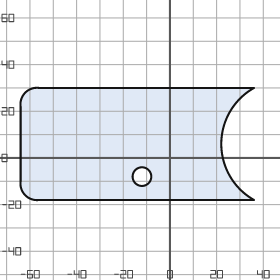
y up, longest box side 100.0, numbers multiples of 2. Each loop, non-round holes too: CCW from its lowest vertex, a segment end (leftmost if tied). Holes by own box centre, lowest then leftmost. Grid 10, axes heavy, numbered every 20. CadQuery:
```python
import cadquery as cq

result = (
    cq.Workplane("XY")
    .moveTo(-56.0, -18.0)
    .lineTo(36.0, -18.0)
    .threePointArc((22.0, 6.0), (36.0, 30.0))
    .lineTo(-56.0, 30.0)
    .threePointArc((-62.0, 28.0), (-64.0, 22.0))
    .lineTo(-64.0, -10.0)
    .threePointArc((-62.0, -16.0), (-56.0, -18.0))
    .close()
    .moveTo(-12.0, -8.0)
    .circle(4.0)
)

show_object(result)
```